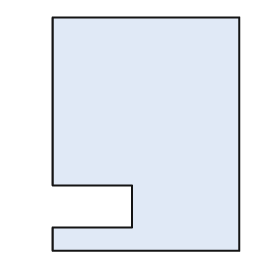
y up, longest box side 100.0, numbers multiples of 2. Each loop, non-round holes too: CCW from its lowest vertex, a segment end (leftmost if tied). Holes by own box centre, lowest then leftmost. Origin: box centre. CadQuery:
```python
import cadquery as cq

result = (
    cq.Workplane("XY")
    .moveTo(-40.0, -50.0)
    .lineTo(40.0, -50.0)
    .lineTo(40.0, 50.0)
    .lineTo(-40.0, 50.0)
    .lineTo(-40.0, -22.0)
    .lineTo(-6.0, -22.0)
    .lineTo(-6.0, -40.0)
    .lineTo(-40.0, -40.0)
    .close()
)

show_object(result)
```